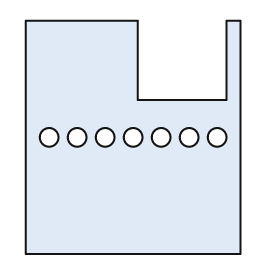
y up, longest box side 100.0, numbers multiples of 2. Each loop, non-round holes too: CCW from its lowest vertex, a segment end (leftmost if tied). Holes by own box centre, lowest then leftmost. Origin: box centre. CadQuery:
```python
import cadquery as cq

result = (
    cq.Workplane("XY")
    .moveTo(-46.0, -50.0)
    .lineTo(46.0, -50.0)
    .lineTo(46.0, 50.0)
    .lineTo(40.0, 50.0)
    .lineTo(40.0, 16.0)
    .lineTo(2.0, 16.0)
    .lineTo(2.0, 50.0)
    .lineTo(-46.0, 50.0)
    .close()
    .moveTo(-36.0, 0.0)
    .circle(4.0)
    .moveTo(-24.0, 0.0)
    .circle(4.0)
    .moveTo(-12.0, 0.0)
    .circle(4.0)
    .moveTo(0.0, 0.0)
    .circle(4.0)
    .moveTo(12.0, 0.0)
    .circle(4.0)
    .moveTo(24.0, 0.0)
    .circle(4.0)
    .moveTo(36.0, 0.0)
    .circle(4.0)
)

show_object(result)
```